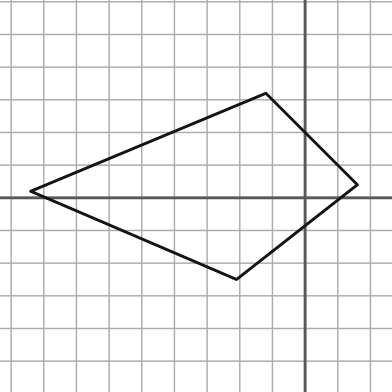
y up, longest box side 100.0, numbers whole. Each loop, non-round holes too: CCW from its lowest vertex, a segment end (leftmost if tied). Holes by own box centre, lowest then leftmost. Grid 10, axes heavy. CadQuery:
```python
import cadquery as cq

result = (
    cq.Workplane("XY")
    .moveTo(-21.0, -25.0)
    .lineTo(16.0, 4.0)
    .lineTo(-12.0, 32.0)
    .lineTo(-84.0, 2.0)
    .close()
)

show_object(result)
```